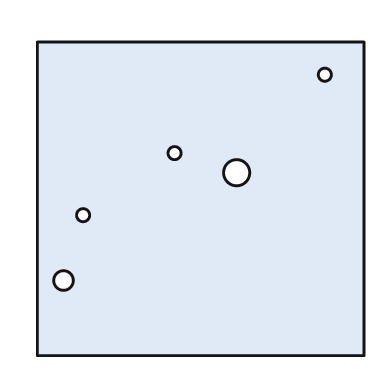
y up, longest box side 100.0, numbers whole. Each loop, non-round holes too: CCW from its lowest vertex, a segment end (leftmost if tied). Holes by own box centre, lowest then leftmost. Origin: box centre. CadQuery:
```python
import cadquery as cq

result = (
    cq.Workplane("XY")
    .moveTo(-50.0, -48.0)
    .lineTo(50.0, -48.0)
    .lineTo(50.0, 48.0)
    .lineTo(-50.0, 48.0)
    .close()
    .moveTo(-42.0, -25.0)
    .circle(3.0)
    .moveTo(-36.0, -5.0)
    .circle(2.0)
    .moveTo(11.0, 8.0)
    .circle(4.0)
    .moveTo(-8.0, 14.0)
    .circle(2.0)
    .moveTo(38.0, 38.0)
    .circle(2.0)
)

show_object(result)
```